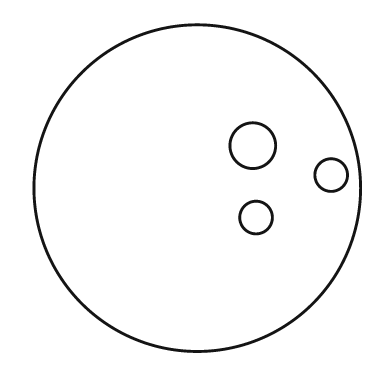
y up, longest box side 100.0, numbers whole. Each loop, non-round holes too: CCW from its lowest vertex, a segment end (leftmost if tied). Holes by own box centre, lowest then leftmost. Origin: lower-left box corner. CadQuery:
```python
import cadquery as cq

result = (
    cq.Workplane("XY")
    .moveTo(50.0, 50.0)
    .circle(50.0)
    .moveTo(68.0, 41.0)
    .circle(5.0)
    .moveTo(91.0, 54.0)
    .circle(5.0)
    .moveTo(67.0, 63.0)
    .circle(7.0)
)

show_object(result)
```